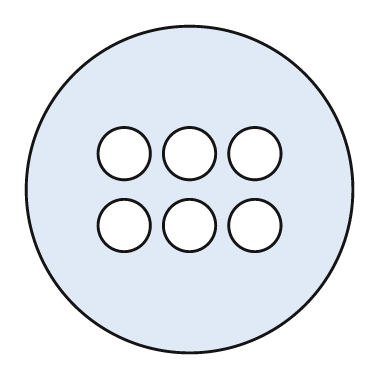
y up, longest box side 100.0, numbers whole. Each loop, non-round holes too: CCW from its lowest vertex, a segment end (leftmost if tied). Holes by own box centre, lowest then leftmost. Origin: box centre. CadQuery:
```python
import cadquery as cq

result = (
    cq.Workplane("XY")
    .moveTo(0.0, 0.0)
    .circle(50.0)
    .moveTo(-20.0, -11.0)
    .circle(8.0)
    .moveTo(0.0, -11.0)
    .circle(8.0)
    .moveTo(20.0, -11.0)
    .circle(8.0)
    .moveTo(-20.0, 11.0)
    .circle(8.0)
    .moveTo(0.0, 11.0)
    .circle(8.0)
    .moveTo(20.0, 11.0)
    .circle(8.0)
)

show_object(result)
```